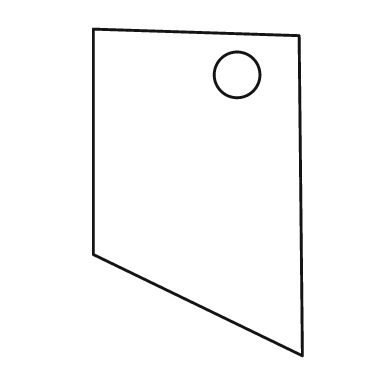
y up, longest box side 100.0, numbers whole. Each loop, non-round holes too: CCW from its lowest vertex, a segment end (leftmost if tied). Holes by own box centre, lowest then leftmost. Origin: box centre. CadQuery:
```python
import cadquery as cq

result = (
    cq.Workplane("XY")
    .moveTo(32.0, -50.0)
    .lineTo(31.0, 48.0)
    .lineTo(-32.0, 50.0)
    .lineTo(-32.0, -19.0)
    .close()
    .moveTo(12.0, 36.0)
    .circle(7.0)
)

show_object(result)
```